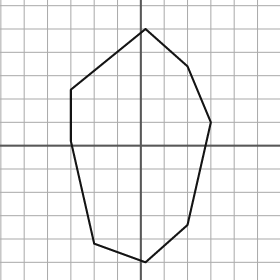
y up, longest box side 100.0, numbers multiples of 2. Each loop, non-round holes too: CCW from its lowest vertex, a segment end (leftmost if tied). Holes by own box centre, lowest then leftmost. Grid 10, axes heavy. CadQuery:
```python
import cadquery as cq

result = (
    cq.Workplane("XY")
    .moveTo(2.0, -50.0)
    .lineTo(20.0, -34.0)
    .lineTo(30.0, 10.0)
    .lineTo(20.0, 34.0)
    .lineTo(2.0, 50.0)
    .lineTo(-30.0, 24.0)
    .lineTo(-30.0, 2.0)
    .lineTo(-20.0, -42.0)
    .close()
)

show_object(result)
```